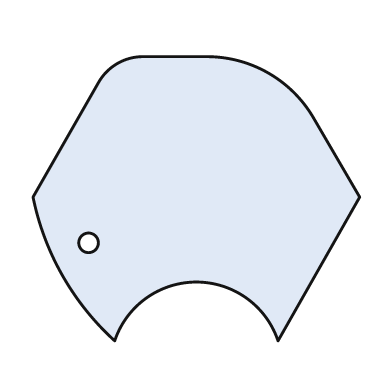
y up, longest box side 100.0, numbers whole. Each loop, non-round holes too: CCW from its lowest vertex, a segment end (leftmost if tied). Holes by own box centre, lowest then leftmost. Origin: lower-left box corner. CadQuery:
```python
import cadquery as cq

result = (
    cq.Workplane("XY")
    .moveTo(25.0, 0.0)
    .threePointArc((50.0, 18.0), (75.0, 0.0))
    .lineTo(100.0, 44.0)
    .lineTo(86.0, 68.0)
    .threePointArc((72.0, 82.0), (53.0, 87.0))
    .lineTo(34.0, 87.0)
    .threePointArc((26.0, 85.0), (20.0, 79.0))
    .lineTo(0.0, 44.0)
    .threePointArc((9.0, 20.0), (25.0, 0.0))
    .close()
    .moveTo(17.0, 30.0)
    .circle(3.0)
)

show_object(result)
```